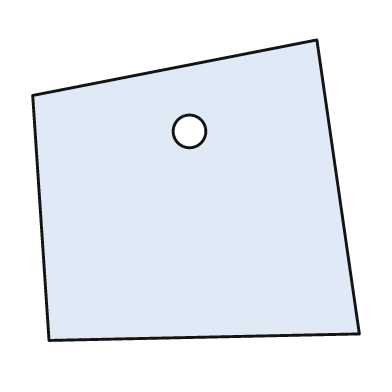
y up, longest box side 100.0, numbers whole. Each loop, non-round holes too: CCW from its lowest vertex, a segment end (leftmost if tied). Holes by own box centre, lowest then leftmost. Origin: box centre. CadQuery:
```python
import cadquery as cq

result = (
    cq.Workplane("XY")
    .moveTo(-45.0, -46.0)
    .lineTo(50.0, -44.0)
    .lineTo(37.0, 46.0)
    .lineTo(-50.0, 29.0)
    .close()
    .moveTo(-2.0, 18.0)
    .circle(5.0)
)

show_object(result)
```